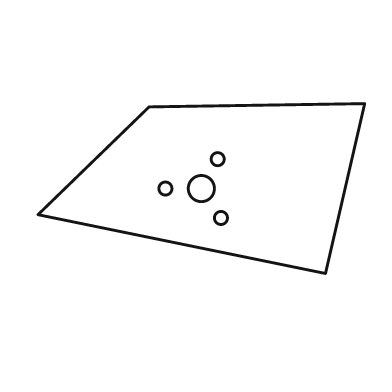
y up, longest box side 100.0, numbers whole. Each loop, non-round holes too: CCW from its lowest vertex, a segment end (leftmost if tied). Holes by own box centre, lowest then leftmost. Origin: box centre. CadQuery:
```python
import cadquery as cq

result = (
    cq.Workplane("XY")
    .moveTo(38.0, -26.0)
    .lineTo(50.0, 26.0)
    .lineTo(-16.0, 25.0)
    .lineTo(-50.0, -8.0)
    .close()
    .moveTo(6.0, -9.0)
    .circle(2.0)
    .moveTo(-11.0, 0.0)
    .circle(2.0)
    .moveTo(0.0, 0.0)
    .circle(4.0)
    .moveTo(5.0, 9.0)
    .circle(2.0)
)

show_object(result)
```